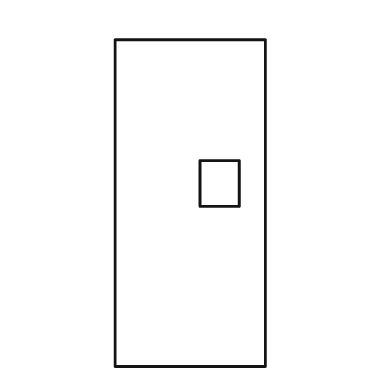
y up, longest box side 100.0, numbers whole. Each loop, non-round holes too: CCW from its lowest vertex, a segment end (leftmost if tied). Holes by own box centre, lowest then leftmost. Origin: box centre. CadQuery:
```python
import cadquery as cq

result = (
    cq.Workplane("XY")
    .moveTo(-23.0, -50.0)
    .lineTo(23.0, -50.0)
    .lineTo(23.0, 50.0)
    .lineTo(-23.0, 50.0)
    .close()
    .moveTo(3.0, -1.0)
    .lineTo(15.0, -1.0)
    .lineTo(15.0, 13.0)
    .lineTo(3.0, 13.0)
    .close()
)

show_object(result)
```